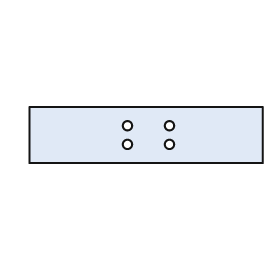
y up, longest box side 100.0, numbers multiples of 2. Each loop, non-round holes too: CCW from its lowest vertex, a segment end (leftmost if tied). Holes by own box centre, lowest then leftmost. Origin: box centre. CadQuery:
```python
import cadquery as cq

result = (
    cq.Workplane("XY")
    .moveTo(-50.0, -12.0)
    .lineTo(50.0, -12.0)
    .lineTo(50.0, 12.0)
    .lineTo(-50.0, 12.0)
    .close()
    .moveTo(-8.0, -4.0)
    .circle(2.0)
    .moveTo(10.0, -4.0)
    .circle(2.0)
    .moveTo(-8.0, 4.0)
    .circle(2.0)
    .moveTo(10.0, 4.0)
    .circle(2.0)
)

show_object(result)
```